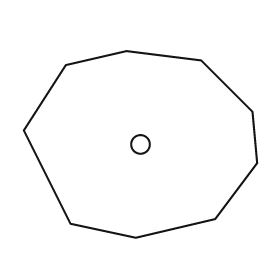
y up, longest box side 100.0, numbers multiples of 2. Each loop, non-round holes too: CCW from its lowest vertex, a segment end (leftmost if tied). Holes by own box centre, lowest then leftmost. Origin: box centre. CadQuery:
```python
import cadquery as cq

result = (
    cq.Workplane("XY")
    .moveTo(-2.0, -40.0)
    .lineTo(32.0, -32.0)
    .lineTo(50.0, -8.0)
    .lineTo(48.0, 14.0)
    .lineTo(26.0, 36.0)
    .lineTo(-6.0, 40.0)
    .lineTo(-32.0, 34.0)
    .lineTo(-50.0, 6.0)
    .lineTo(-30.0, -34.0)
    .close()
    .moveTo(0.0, 0.0)
    .circle(4.0)
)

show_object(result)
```